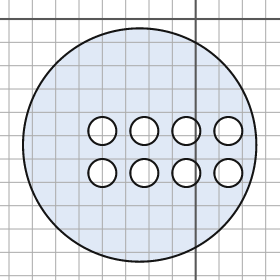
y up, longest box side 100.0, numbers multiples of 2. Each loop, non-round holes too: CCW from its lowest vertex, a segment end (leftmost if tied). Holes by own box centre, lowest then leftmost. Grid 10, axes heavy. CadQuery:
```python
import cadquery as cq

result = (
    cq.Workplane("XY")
    .moveTo(-24.0, -54.0)
    .circle(50.0)
    .moveTo(-40.0, -66.0)
    .circle(6.0)
    .moveTo(-22.0, -66.0)
    .circle(6.0)
    .moveTo(-4.0, -66.0)
    .circle(6.0)
    .moveTo(14.0, -66.0)
    .circle(6.0)
    .moveTo(-40.0, -48.0)
    .circle(6.0)
    .moveTo(-22.0, -48.0)
    .circle(6.0)
    .moveTo(-4.0, -48.0)
    .circle(6.0)
    .moveTo(14.0, -48.0)
    .circle(6.0)
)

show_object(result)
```